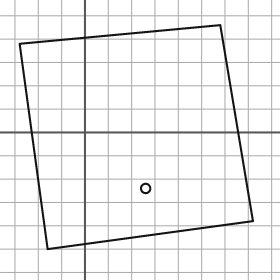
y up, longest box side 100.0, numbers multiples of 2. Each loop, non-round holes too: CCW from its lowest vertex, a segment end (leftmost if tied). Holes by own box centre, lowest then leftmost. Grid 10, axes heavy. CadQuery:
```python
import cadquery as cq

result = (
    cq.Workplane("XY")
    .moveTo(-16.0, -50.0)
    .lineTo(72.0, -38.0)
    .lineTo(58.0, 46.0)
    .lineTo(-28.0, 38.0)
    .close()
    .moveTo(26.0, -24.0)
    .circle(2.0)
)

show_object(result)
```